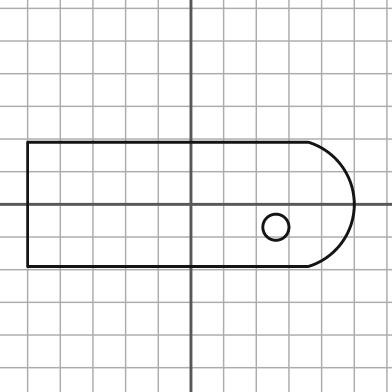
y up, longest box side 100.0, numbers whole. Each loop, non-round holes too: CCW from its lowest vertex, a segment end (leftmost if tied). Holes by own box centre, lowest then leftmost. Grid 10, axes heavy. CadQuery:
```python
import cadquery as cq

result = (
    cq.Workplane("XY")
    .moveTo(-50.0, -19.0)
    .lineTo(36.0, -19.0)
    .threePointArc((50.0, 0.0), (36.0, 19.0))
    .lineTo(-50.0, 19.0)
    .close()
    .moveTo(26.0, -7.0)
    .circle(4.0)
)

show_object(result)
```